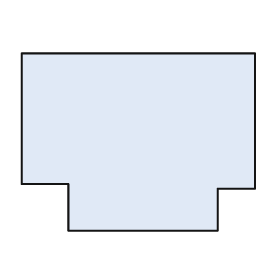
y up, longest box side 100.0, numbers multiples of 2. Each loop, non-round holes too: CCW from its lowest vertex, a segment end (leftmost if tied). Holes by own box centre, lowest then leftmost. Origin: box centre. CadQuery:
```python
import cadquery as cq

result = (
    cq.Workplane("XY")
    .moveTo(-30.0, -38.0)
    .lineTo(34.0, -38.0)
    .lineTo(34.0, -20.0)
    .lineTo(50.0, -20.0)
    .lineTo(50.0, 38.0)
    .lineTo(-50.0, 38.0)
    .lineTo(-50.0, -18.0)
    .lineTo(-30.0, -18.0)
    .close()
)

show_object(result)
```